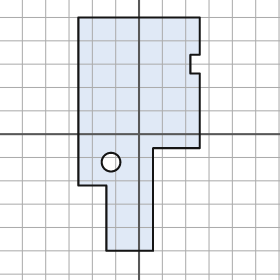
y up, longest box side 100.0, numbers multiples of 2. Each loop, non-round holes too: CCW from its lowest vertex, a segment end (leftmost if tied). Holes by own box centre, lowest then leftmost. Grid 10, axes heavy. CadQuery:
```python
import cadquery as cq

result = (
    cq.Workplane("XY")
    .moveTo(-14.0, -50.0)
    .lineTo(6.0, -50.0)
    .lineTo(6.0, -6.0)
    .lineTo(26.0, -6.0)
    .lineTo(26.0, 26.0)
    .lineTo(22.0, 26.0)
    .lineTo(22.0, 34.0)
    .lineTo(26.0, 34.0)
    .lineTo(26.0, 50.0)
    .lineTo(-26.0, 50.0)
    .lineTo(-26.0, -22.0)
    .lineTo(-14.0, -22.0)
    .close()
    .moveTo(-12.0, -12.0)
    .circle(4.0)
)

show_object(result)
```